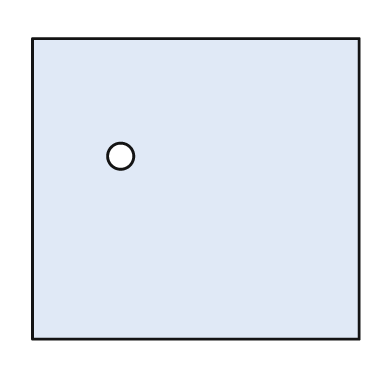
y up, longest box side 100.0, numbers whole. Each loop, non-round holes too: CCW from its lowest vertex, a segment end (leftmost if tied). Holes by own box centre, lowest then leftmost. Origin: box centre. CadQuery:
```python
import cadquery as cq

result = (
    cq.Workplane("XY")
    .moveTo(-50.0, -46.0)
    .lineTo(50.0, -46.0)
    .lineTo(50.0, 46.0)
    .lineTo(-50.0, 46.0)
    .close()
    .moveTo(-23.0, 10.0)
    .circle(4.0)
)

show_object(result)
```